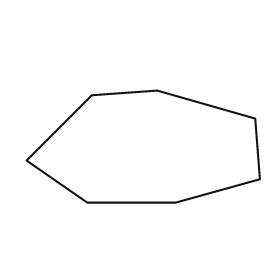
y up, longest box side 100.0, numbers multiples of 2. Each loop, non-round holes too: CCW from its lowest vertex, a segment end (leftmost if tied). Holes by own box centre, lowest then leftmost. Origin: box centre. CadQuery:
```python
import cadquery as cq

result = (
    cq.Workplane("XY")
    .moveTo(-24.0, -24.0)
    .lineTo(14.0, -24.0)
    .lineTo(50.0, -14.0)
    .lineTo(48.0, 12.0)
    .lineTo(6.0, 24.0)
    .lineTo(-22.0, 22.0)
    .lineTo(-50.0, -6.0)
    .close()
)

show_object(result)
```